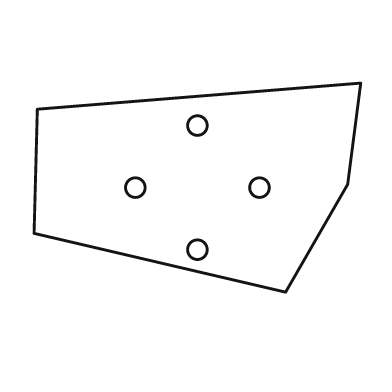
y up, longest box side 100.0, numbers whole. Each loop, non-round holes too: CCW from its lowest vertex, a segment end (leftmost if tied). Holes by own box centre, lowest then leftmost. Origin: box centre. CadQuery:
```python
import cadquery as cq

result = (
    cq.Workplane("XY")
    .moveTo(27.0, -32.0)
    .lineTo(46.0, 1.0)
    .lineTo(50.0, 32.0)
    .lineTo(-49.0, 24.0)
    .lineTo(-50.0, -14.0)
    .close()
    .moveTo(0.0, -19.0)
    .circle(3.0)
    .moveTo(-19.0, 0.0)
    .circle(3.0)
    .moveTo(19.0, 0.0)
    .circle(3.0)
    .moveTo(0.0, 19.0)
    .circle(3.0)
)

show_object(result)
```